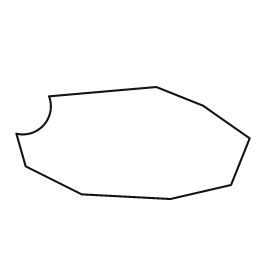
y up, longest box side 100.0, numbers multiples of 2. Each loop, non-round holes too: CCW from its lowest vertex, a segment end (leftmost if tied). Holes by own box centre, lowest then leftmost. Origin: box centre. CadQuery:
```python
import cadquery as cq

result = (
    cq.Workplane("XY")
    .moveTo(16.0, -24.0)
    .lineTo(42.0, -18.0)
    .lineTo(50.0, 2.0)
    .lineTo(30.0, 16.0)
    .lineTo(10.0, 24.0)
    .lineTo(-36.0, 20.0)
    .threePointArc((-38.0, 8.0), (-50.0, 4.0))
    .lineTo(-46.0, -10.0)
    .lineTo(-22.0, -22.0)
    .close()
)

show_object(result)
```